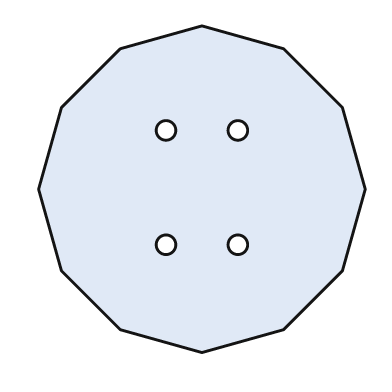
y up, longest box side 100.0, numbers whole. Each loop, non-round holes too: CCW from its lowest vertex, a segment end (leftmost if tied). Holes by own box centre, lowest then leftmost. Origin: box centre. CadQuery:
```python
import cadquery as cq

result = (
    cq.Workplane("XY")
    .moveTo(0.0, -50.0)
    .lineTo(25.0, -43.0)
    .lineTo(43.0, -25.0)
    .lineTo(50.0, 0.0)
    .lineTo(43.0, 25.0)
    .lineTo(25.0, 43.0)
    .lineTo(0.0, 50.0)
    .lineTo(-25.0, 43.0)
    .lineTo(-43.0, 25.0)
    .lineTo(-50.0, 0.0)
    .lineTo(-43.0, -25.0)
    .lineTo(-25.0, -43.0)
    .close()
    .moveTo(-11.0, -17.0)
    .circle(3.0)
    .moveTo(11.0, -17.0)
    .circle(3.0)
    .moveTo(-11.0, 18.0)
    .circle(3.0)
    .moveTo(11.0, 18.0)
    .circle(3.0)
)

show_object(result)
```